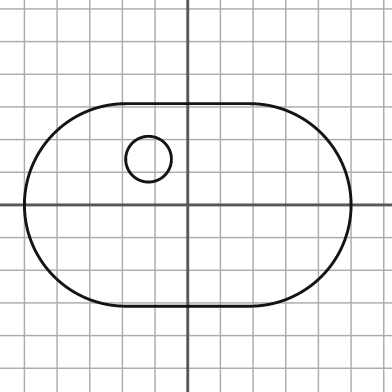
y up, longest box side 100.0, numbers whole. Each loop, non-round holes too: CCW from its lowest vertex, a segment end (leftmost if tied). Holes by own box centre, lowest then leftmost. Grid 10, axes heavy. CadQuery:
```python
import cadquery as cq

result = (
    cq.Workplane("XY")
    .moveTo(-19.0, -31.0)
    .lineTo(19.0, -31.0)
    .threePointArc((50.0, 0.0), (19.0, 31.0))
    .lineTo(-19.0, 31.0)
    .threePointArc((-50.0, 0.0), (-19.0, -31.0))
    .close()
    .moveTo(-12.0, 14.0)
    .circle(7.0)
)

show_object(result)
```